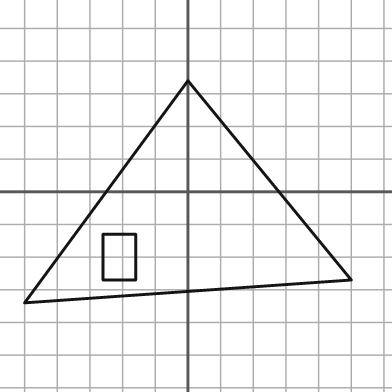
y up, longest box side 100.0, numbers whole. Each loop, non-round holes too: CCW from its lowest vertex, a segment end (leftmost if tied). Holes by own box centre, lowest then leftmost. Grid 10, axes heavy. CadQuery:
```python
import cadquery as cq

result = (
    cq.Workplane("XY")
    .moveTo(-50.0, -34.0)
    .lineTo(50.0, -27.0)
    .lineTo(0.0, 34.0)
    .close()
    .moveTo(-26.0, -27.0)
    .lineTo(-16.0, -27.0)
    .lineTo(-16.0, -13.0)
    .lineTo(-26.0, -13.0)
    .close()
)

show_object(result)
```